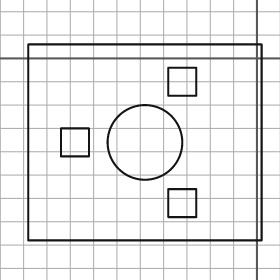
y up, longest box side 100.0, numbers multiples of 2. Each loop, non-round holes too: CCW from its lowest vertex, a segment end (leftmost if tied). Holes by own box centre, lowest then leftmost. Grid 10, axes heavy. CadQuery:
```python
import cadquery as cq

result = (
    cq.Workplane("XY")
    .moveTo(-98.0, -78.0)
    .lineTo(2.0, -78.0)
    .lineTo(2.0, 6.0)
    .lineTo(-98.0, 6.0)
    .close()
    .moveTo(-38.0, -68.0)
    .lineTo(-26.0, -68.0)
    .lineTo(-26.0, -56.0)
    .lineTo(-38.0, -56.0)
    .close()
    .moveTo(-84.0, -42.0)
    .lineTo(-72.0, -42.0)
    .lineTo(-72.0, -30.0)
    .lineTo(-84.0, -30.0)
    .close()
    .moveTo(-48.0, -36.0)
    .circle(16.0)
    .moveTo(-38.0, -16.0)
    .lineTo(-26.0, -16.0)
    .lineTo(-26.0, -4.0)
    .lineTo(-38.0, -4.0)
    .close()
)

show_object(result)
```